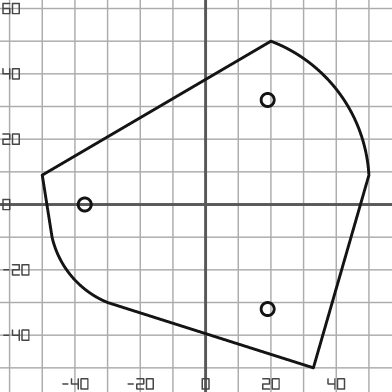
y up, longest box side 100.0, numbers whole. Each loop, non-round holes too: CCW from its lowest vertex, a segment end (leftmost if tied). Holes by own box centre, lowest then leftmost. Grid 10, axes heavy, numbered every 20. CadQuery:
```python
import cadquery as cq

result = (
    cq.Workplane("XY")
    .moveTo(33.0, -50.0)
    .lineTo(50.0, 9.0)
    .threePointArc((41.0, 34.0), (20.0, 50.0))
    .lineTo(-50.0, 9.0)
    .lineTo(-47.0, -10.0)
    .threePointArc((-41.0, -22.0), (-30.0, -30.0))
    .close()
    .moveTo(19.0, -32.0)
    .circle(2.0)
    .moveTo(-37.0, 0.0)
    .circle(2.0)
    .moveTo(19.0, 32.0)
    .circle(2.0)
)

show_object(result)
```